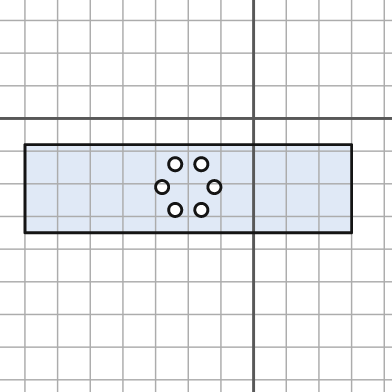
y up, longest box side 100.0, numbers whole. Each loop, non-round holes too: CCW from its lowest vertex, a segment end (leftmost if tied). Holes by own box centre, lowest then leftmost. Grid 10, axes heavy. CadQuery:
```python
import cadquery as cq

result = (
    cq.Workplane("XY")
    .moveTo(-70.0, -35.0)
    .lineTo(30.0, -35.0)
    .lineTo(30.0, -8.0)
    .lineTo(-70.0, -8.0)
    .close()
    .moveTo(-24.0, -28.0)
    .circle(2.0)
    .moveTo(-16.0, -28.0)
    .circle(2.0)
    .moveTo(-28.0, -21.0)
    .circle(2.0)
    .moveTo(-12.0, -21.0)
    .circle(2.0)
    .moveTo(-24.0, -14.0)
    .circle(2.0)
    .moveTo(-16.0, -14.0)
    .circle(2.0)
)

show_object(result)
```